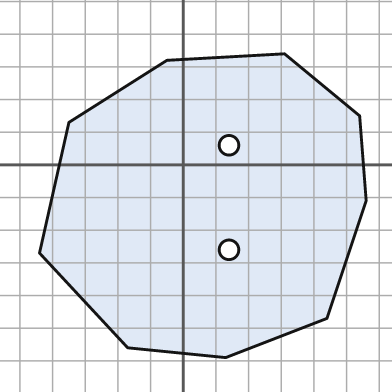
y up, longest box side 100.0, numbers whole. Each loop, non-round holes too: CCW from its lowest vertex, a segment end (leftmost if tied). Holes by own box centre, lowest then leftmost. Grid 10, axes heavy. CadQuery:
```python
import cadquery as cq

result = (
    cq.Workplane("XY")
    .moveTo(13.0, -59.0)
    .lineTo(44.0, -47.0)
    .lineTo(56.0, -11.0)
    .lineTo(54.0, 15.0)
    .lineTo(31.0, 34.0)
    .lineTo(-5.0, 32.0)
    .lineTo(-35.0, 13.0)
    .lineTo(-44.0, -27.0)
    .lineTo(-17.0, -56.0)
    .close()
    .moveTo(14.0, -26.0)
    .circle(3.0)
    .moveTo(14.0, 6.0)
    .circle(3.0)
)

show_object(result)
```